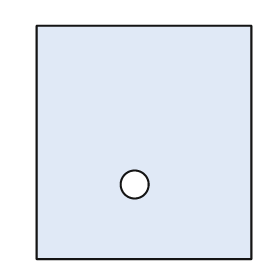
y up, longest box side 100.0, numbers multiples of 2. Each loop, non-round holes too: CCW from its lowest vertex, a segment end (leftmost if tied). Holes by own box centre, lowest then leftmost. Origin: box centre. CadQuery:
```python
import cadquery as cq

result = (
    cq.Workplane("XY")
    .moveTo(-46.0, -50.0)
    .lineTo(46.0, -50.0)
    .lineTo(46.0, 50.0)
    .lineTo(-46.0, 50.0)
    .close()
    .moveTo(-4.0, -18.0)
    .circle(6.0)
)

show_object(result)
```